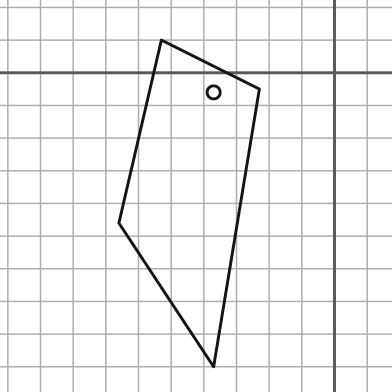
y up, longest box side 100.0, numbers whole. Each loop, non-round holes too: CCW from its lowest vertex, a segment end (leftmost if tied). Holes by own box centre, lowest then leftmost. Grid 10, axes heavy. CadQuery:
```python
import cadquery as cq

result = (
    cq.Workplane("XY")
    .moveTo(-37.0, -90.0)
    .lineTo(-23.0, -5.0)
    .lineTo(-53.0, 10.0)
    .lineTo(-66.0, -46.0)
    .close()
    .moveTo(-37.0, -6.0)
    .circle(2.0)
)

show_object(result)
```